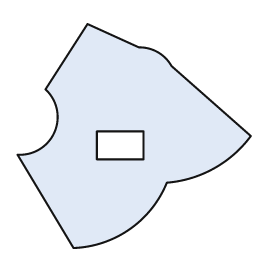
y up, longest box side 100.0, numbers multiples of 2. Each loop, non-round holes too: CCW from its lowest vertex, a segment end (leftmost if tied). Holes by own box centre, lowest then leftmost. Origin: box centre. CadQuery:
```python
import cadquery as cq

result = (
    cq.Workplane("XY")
    .moveTo(-26.0, -48.0)
    .threePointArc((-2.0, -40.0), (14.0, -20.0))
    .threePointArc((34.0, -14.0), (50.0, 0.0))
    .lineTo(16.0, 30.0)
    .threePointArc((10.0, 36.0), (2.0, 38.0))
    .lineTo(-20.0, 48.0)
    .lineTo(-38.0, 20.0)
    .threePointArc((-34.0, 2.0), (-50.0, -8.0))
    .close()
    .moveTo(-16.0, -10.0)
    .lineTo(4.0, -10.0)
    .lineTo(4.0, 2.0)
    .lineTo(-16.0, 2.0)
    .close()
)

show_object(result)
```